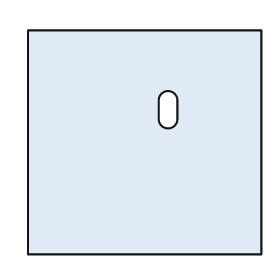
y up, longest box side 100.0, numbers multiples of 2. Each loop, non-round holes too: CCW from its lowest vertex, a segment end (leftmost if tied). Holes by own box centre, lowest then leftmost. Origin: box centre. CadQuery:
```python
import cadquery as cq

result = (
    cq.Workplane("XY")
    .moveTo(-50.0, -48.0)
    .lineTo(50.0, -48.0)
    .lineTo(50.0, 48.0)
    .lineTo(-50.0, 48.0)
    .close()
    .moveTo(6.0, 10.0)
    .threePointArc((10.0, 6.0), (14.0, 10.0))
    .lineTo(14.0, 18.0)
    .threePointArc((10.0, 22.0), (6.0, 18.0))
    .close()
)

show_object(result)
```